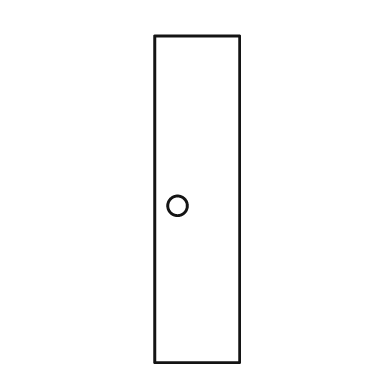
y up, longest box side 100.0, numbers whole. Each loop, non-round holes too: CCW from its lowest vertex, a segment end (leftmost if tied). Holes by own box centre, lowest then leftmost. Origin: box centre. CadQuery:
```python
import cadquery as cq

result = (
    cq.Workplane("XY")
    .moveTo(-13.0, -50.0)
    .lineTo(13.0, -50.0)
    .lineTo(13.0, 50.0)
    .lineTo(-13.0, 50.0)
    .close()
    .moveTo(-6.0, -2.0)
    .circle(3.0)
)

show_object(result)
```